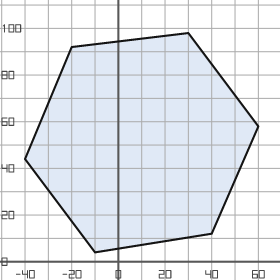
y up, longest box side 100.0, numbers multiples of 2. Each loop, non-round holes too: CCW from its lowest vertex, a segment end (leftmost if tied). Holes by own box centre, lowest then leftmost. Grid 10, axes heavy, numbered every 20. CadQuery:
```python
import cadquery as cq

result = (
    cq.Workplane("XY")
    .moveTo(-10.0, 4.0)
    .lineTo(40.0, 12.0)
    .lineTo(60.0, 58.0)
    .lineTo(30.0, 98.0)
    .lineTo(-20.0, 92.0)
    .lineTo(-40.0, 44.0)
    .close()
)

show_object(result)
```